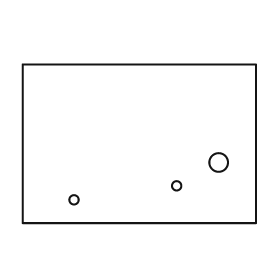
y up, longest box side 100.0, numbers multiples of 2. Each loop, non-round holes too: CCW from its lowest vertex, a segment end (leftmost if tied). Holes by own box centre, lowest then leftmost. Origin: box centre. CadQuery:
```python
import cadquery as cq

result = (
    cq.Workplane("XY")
    .moveTo(-50.0, -34.0)
    .lineTo(50.0, -34.0)
    .lineTo(50.0, 34.0)
    .lineTo(-50.0, 34.0)
    .close()
    .moveTo(-28.0, -24.0)
    .circle(2.0)
    .moveTo(16.0, -18.0)
    .circle(2.0)
    .moveTo(34.0, -8.0)
    .circle(4.0)
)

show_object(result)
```